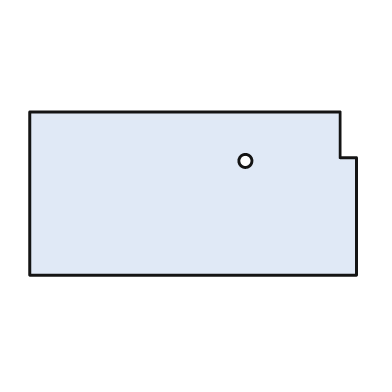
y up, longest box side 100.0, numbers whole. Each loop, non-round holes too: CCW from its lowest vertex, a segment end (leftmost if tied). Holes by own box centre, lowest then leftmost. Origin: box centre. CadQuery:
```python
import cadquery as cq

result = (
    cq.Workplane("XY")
    .moveTo(-50.0, -25.0)
    .lineTo(50.0, -25.0)
    .lineTo(50.0, 11.0)
    .lineTo(45.0, 11.0)
    .lineTo(45.0, 25.0)
    .lineTo(-50.0, 25.0)
    .close()
    .moveTo(16.0, 10.0)
    .circle(2.0)
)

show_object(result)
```